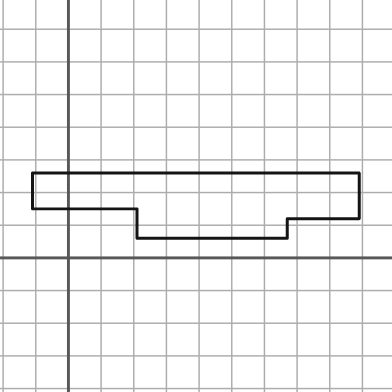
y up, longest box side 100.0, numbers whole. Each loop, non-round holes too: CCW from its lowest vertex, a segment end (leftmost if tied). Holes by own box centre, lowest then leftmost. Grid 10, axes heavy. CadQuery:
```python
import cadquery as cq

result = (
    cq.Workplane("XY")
    .moveTo(21.0, 6.0)
    .lineTo(67.0, 6.0)
    .lineTo(67.0, 12.0)
    .lineTo(89.0, 12.0)
    .lineTo(89.0, 26.0)
    .lineTo(-11.0, 26.0)
    .lineTo(-11.0, 15.0)
    .lineTo(21.0, 15.0)
    .close()
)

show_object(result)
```